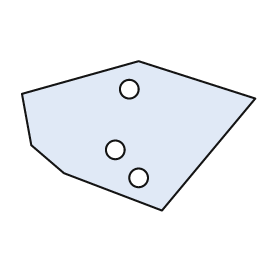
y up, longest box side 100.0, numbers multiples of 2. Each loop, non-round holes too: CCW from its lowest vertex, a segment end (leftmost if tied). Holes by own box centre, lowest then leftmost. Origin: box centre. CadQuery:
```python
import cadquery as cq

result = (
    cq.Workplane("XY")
    .moveTo(10.0, -32.0)
    .lineTo(50.0, 16.0)
    .lineTo(0.0, 32.0)
    .lineTo(-50.0, 18.0)
    .lineTo(-46.0, -4.0)
    .lineTo(-32.0, -16.0)
    .close()
    .moveTo(0.0, -18.0)
    .circle(4.0)
    .moveTo(-10.0, -6.0)
    .circle(4.0)
    .moveTo(-4.0, 20.0)
    .circle(4.0)
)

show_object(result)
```